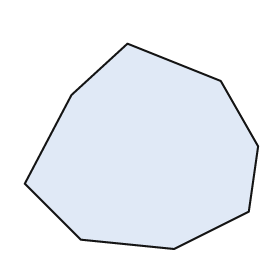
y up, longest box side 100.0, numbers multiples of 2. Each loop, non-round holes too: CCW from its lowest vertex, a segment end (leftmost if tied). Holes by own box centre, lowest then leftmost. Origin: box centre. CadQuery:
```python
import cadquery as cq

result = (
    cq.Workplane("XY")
    .moveTo(14.0, -44.0)
    .lineTo(46.0, -28.0)
    .lineTo(50.0, 0.0)
    .lineTo(34.0, 28.0)
    .lineTo(-6.0, 44.0)
    .lineTo(-30.0, 22.0)
    .lineTo(-50.0, -16.0)
    .lineTo(-26.0, -40.0)
    .close()
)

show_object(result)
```